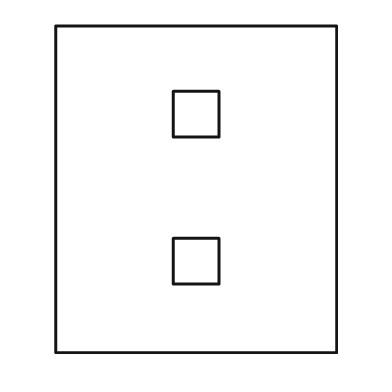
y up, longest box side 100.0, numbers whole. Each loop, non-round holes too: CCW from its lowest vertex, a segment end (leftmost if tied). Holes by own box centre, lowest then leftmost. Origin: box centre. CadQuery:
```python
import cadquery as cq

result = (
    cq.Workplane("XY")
    .moveTo(-43.0, -50.0)
    .lineTo(43.0, -50.0)
    .lineTo(43.0, 50.0)
    .lineTo(-43.0, 50.0)
    .close()
    .moveTo(-7.0, -29.0)
    .lineTo(7.0, -29.0)
    .lineTo(7.0, -15.0)
    .lineTo(-7.0, -15.0)
    .close()
    .moveTo(-7.0, 16.0)
    .lineTo(7.0, 16.0)
    .lineTo(7.0, 30.0)
    .lineTo(-7.0, 30.0)
    .close()
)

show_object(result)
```